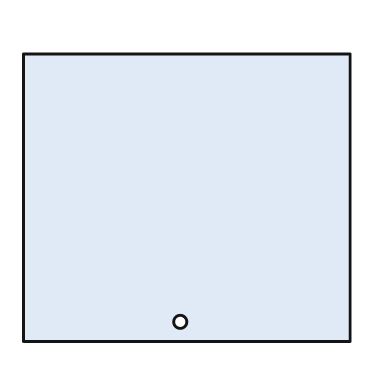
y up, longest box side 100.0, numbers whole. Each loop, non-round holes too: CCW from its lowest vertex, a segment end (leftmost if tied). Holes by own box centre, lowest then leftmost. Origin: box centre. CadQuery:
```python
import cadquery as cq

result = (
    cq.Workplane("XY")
    .moveTo(-50.0, -44.0)
    .lineTo(50.0, -44.0)
    .lineTo(50.0, 44.0)
    .lineTo(-50.0, 44.0)
    .close()
    .moveTo(-2.0, -38.0)
    .circle(2.0)
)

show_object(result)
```